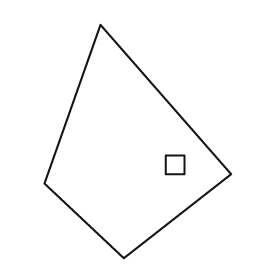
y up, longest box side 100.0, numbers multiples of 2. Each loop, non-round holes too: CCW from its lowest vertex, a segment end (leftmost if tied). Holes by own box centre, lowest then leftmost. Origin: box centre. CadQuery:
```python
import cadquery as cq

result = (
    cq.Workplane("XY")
    .moveTo(-6.0, -50.0)
    .lineTo(40.0, -14.0)
    .lineTo(-16.0, 50.0)
    .lineTo(-40.0, -18.0)
    .close()
    .moveTo(12.0, -14.0)
    .lineTo(20.0, -14.0)
    .lineTo(20.0, -6.0)
    .lineTo(12.0, -6.0)
    .close()
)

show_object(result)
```